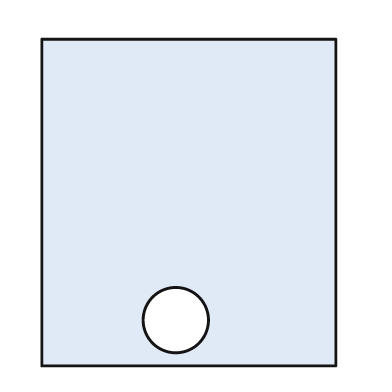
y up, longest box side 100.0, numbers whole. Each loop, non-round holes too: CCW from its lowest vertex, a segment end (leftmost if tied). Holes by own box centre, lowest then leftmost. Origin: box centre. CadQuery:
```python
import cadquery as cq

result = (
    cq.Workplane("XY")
    .moveTo(-45.0, -50.0)
    .lineTo(45.0, -50.0)
    .lineTo(45.0, 50.0)
    .lineTo(-45.0, 50.0)
    .close()
    .moveTo(-4.0, -36.0)
    .circle(10.0)
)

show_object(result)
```